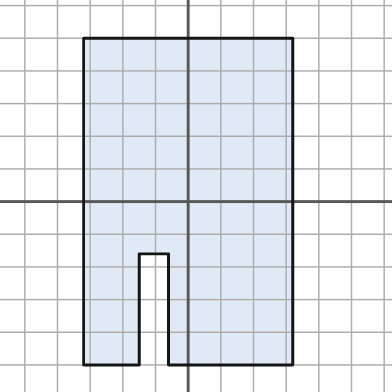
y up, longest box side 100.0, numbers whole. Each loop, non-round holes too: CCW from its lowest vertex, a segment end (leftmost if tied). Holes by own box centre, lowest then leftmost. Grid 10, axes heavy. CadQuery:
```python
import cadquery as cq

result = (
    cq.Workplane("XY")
    .moveTo(-32.0, -50.0)
    .lineTo(-15.0, -50.0)
    .lineTo(-15.0, -16.0)
    .lineTo(-6.0, -16.0)
    .lineTo(-6.0, -50.0)
    .lineTo(32.0, -50.0)
    .lineTo(32.0, 50.0)
    .lineTo(-32.0, 50.0)
    .close()
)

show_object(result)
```